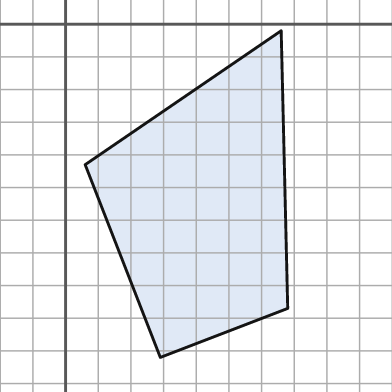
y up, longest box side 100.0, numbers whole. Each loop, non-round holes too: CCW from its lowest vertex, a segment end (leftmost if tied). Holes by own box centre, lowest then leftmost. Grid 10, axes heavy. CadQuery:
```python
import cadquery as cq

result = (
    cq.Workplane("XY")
    .moveTo(29.0, -102.0)
    .lineTo(68.0, -87.0)
    .lineTo(66.0, -2.0)
    .lineTo(6.0, -43.0)
    .close()
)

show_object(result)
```